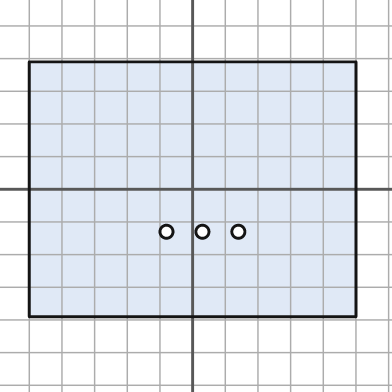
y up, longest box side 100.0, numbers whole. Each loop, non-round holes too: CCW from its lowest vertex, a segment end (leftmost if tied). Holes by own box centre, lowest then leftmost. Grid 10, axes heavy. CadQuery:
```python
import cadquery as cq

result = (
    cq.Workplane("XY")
    .moveTo(-50.0, -39.0)
    .lineTo(50.0, -39.0)
    .lineTo(50.0, 39.0)
    .lineTo(-50.0, 39.0)
    .close()
    .moveTo(-8.0, -13.0)
    .circle(2.0)
    .moveTo(3.0, -13.0)
    .circle(2.0)
    .moveTo(14.0, -13.0)
    .circle(2.0)
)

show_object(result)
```